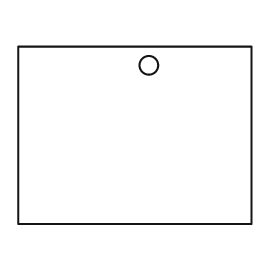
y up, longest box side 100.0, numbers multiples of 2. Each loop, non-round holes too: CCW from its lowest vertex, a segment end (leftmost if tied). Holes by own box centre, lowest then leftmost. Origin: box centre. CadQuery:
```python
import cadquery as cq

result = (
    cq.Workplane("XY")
    .moveTo(-50.0, -38.0)
    .lineTo(50.0, -38.0)
    .lineTo(50.0, 38.0)
    .lineTo(-50.0, 38.0)
    .close()
    .moveTo(6.0, 30.0)
    .circle(4.0)
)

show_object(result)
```